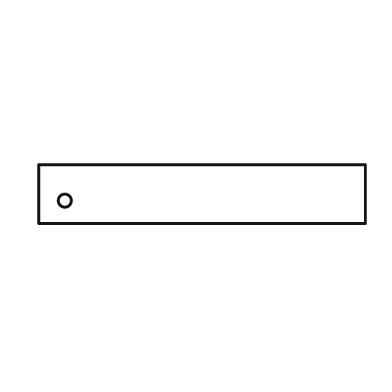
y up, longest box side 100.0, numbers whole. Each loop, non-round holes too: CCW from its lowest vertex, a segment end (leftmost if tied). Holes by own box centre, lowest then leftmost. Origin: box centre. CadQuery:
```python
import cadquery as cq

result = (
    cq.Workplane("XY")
    .moveTo(-50.0, -9.0)
    .lineTo(50.0, -9.0)
    .lineTo(50.0, 9.0)
    .lineTo(-50.0, 9.0)
    .close()
    .moveTo(-42.0, -2.0)
    .circle(2.0)
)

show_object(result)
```